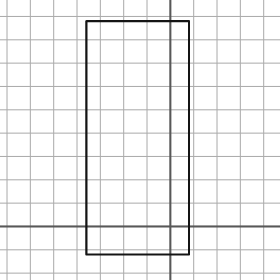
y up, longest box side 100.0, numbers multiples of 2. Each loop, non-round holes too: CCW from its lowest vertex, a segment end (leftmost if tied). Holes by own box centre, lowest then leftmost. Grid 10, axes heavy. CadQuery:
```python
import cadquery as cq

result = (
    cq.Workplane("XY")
    .moveTo(-36.0, -12.0)
    .lineTo(8.0, -12.0)
    .lineTo(8.0, 88.0)
    .lineTo(-36.0, 88.0)
    .close()
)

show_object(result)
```